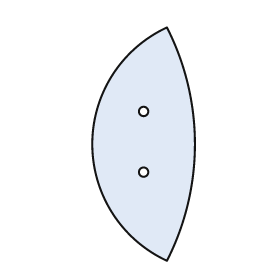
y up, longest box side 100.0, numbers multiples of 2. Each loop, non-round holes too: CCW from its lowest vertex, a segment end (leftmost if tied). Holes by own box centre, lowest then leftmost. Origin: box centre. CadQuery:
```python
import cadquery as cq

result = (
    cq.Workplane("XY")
    .moveTo(10.0, -50.0)
    .threePointArc((22.0, 0.0), (10.0, 50.0))
    .threePointArc((-22.0, 0.0), (10.0, -50.0))
    .close()
    .moveTo(0.0, -12.0)
    .circle(2.0)
    .moveTo(0.0, 14.0)
    .circle(2.0)
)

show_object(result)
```